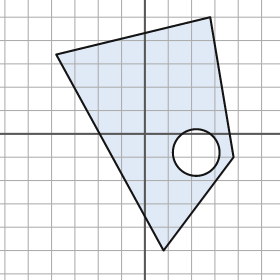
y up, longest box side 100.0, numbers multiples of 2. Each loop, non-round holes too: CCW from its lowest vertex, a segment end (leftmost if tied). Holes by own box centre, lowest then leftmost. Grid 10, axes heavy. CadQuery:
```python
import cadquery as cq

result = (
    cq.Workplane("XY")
    .moveTo(8.0, -50.0)
    .lineTo(38.0, -10.0)
    .lineTo(28.0, 50.0)
    .lineTo(-38.0, 34.0)
    .close()
    .moveTo(22.0, -8.0)
    .circle(10.0)
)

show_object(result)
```